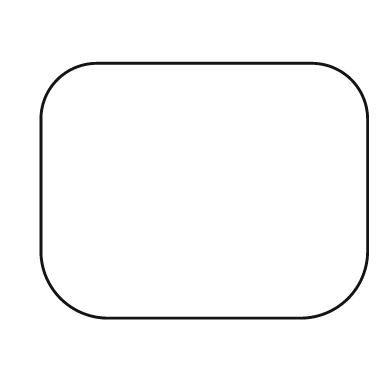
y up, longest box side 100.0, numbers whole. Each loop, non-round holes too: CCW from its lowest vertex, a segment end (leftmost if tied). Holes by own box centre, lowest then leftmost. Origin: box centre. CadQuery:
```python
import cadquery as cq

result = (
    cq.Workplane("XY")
    .moveTo(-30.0, -39.0)
    .lineTo(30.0, -39.0)
    .threePointArc((44.0, -33.0), (50.0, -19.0))
    .lineTo(50.0, 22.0)
    .threePointArc((45.0, 34.0), (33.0, 39.0))
    .lineTo(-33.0, 39.0)
    .threePointArc((-45.0, 34.0), (-50.0, 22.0))
    .lineTo(-50.0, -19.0)
    .threePointArc((-44.0, -33.0), (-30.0, -39.0))
    .close()
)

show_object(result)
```